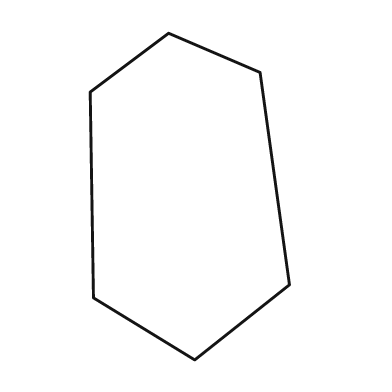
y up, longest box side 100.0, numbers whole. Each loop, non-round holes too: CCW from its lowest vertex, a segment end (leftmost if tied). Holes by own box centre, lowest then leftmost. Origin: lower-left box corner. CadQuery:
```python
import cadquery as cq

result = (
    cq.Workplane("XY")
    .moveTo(32.0, 0.0)
    .lineTo(61.0, 23.0)
    .lineTo(52.0, 88.0)
    .lineTo(24.0, 100.0)
    .lineTo(0.0, 82.0)
    .lineTo(1.0, 19.0)
    .close()
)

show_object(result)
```